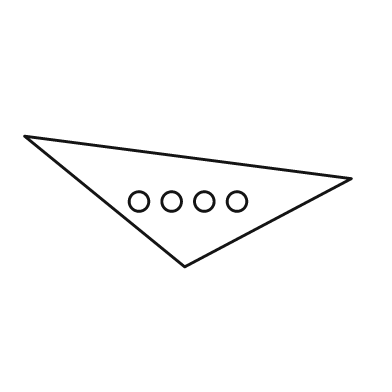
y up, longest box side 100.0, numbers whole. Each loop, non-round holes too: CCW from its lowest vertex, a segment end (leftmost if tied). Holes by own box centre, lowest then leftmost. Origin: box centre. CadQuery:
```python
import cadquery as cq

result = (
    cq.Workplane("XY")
    .moveTo(-1.0, -20.0)
    .lineTo(50.0, 7.0)
    .lineTo(-50.0, 20.0)
    .close()
    .moveTo(-15.0, 0.0)
    .circle(3.0)
    .moveTo(-5.0, 0.0)
    .circle(3.0)
    .moveTo(5.0, 0.0)
    .circle(3.0)
    .moveTo(15.0, 0.0)
    .circle(3.0)
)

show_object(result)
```